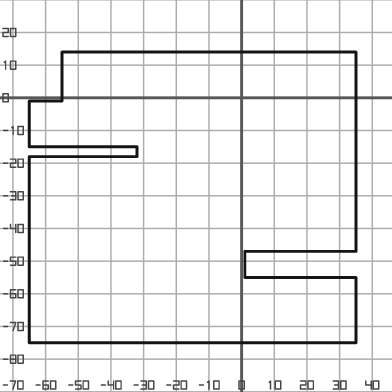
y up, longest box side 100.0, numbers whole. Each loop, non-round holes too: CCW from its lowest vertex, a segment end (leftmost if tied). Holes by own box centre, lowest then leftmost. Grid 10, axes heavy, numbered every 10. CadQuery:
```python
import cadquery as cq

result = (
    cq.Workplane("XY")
    .moveTo(-65.0, -75.0)
    .lineTo(35.0, -75.0)
    .lineTo(35.0, -55.0)
    .lineTo(1.0, -55.0)
    .lineTo(1.0, -47.0)
    .lineTo(35.0, -47.0)
    .lineTo(35.0, 14.0)
    .lineTo(-55.0, 14.0)
    .lineTo(-55.0, -1.0)
    .lineTo(-65.0, -1.0)
    .lineTo(-65.0, -15.0)
    .lineTo(-32.0, -15.0)
    .lineTo(-32.0, -18.0)
    .lineTo(-65.0, -18.0)
    .close()
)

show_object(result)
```